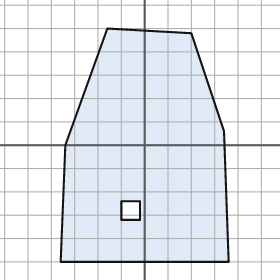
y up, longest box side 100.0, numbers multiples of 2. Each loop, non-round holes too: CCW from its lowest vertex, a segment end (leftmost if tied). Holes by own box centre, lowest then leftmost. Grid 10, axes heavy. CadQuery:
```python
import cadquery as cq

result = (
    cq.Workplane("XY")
    .moveTo(-36.0, -50.0)
    .lineTo(36.0, -50.0)
    .lineTo(34.0, 6.0)
    .lineTo(20.0, 48.0)
    .lineTo(-16.0, 50.0)
    .lineTo(-34.0, 0.0)
    .close()
    .moveTo(-10.0, -32.0)
    .lineTo(-2.0, -32.0)
    .lineTo(-2.0, -24.0)
    .lineTo(-10.0, -24.0)
    .close()
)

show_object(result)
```